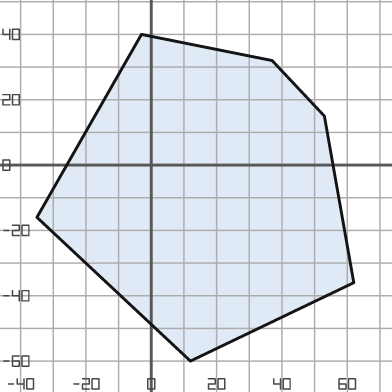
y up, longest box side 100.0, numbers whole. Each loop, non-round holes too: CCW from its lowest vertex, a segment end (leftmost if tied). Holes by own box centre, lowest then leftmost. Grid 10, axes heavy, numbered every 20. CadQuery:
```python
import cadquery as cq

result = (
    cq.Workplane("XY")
    .moveTo(12.0, -60.0)
    .lineTo(62.0, -36.0)
    .lineTo(53.0, 15.0)
    .lineTo(37.0, 32.0)
    .lineTo(-3.0, 40.0)
    .lineTo(-35.0, -16.0)
    .close()
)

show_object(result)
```